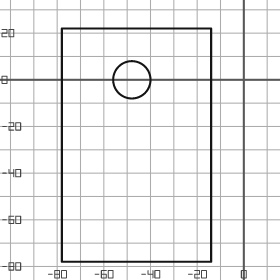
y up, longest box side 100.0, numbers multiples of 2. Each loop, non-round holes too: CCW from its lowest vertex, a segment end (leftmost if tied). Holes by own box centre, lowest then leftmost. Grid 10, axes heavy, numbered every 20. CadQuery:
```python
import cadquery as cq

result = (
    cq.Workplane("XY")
    .moveTo(-78.0, -78.0)
    .lineTo(-14.0, -78.0)
    .lineTo(-14.0, 22.0)
    .lineTo(-78.0, 22.0)
    .close()
    .moveTo(-48.0, 0.0)
    .circle(8.0)
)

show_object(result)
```